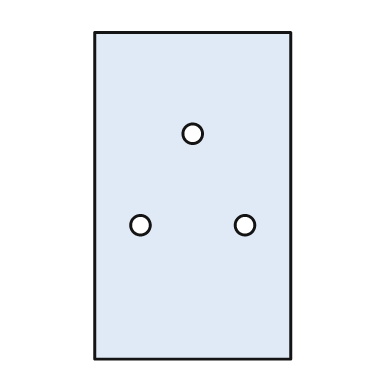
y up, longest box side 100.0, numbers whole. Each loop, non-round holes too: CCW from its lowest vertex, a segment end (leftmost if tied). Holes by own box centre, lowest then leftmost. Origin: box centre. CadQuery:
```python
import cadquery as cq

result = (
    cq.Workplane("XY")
    .moveTo(-30.0, -50.0)
    .lineTo(30.0, -50.0)
    .lineTo(30.0, 50.0)
    .lineTo(-30.0, 50.0)
    .close()
    .moveTo(-16.0, -9.0)
    .circle(3.0)
    .moveTo(16.0, -9.0)
    .circle(3.0)
    .moveTo(0.0, 19.0)
    .circle(3.0)
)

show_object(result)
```